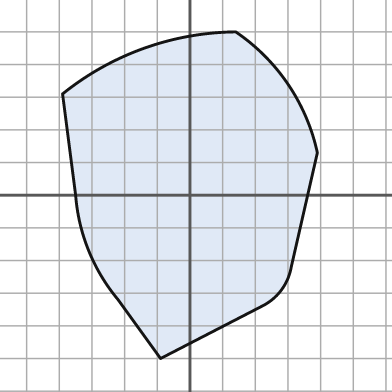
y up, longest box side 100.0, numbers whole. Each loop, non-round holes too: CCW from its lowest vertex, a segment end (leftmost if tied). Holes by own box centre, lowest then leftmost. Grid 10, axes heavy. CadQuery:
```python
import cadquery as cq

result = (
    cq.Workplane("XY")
    .moveTo(-9.0, -50.0)
    .lineTo(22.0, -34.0)
    .threePointArc((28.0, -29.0), (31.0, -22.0))
    .lineTo(39.0, 13.0)
    .threePointArc((30.0, 34.0), (14.0, 50.0))
    .threePointArc((-14.0, 45.0), (-39.0, 31.0))
    .lineTo(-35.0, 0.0)
    .threePointArc((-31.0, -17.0), (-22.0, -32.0))
    .close()
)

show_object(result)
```